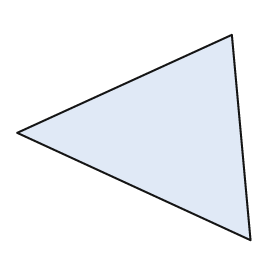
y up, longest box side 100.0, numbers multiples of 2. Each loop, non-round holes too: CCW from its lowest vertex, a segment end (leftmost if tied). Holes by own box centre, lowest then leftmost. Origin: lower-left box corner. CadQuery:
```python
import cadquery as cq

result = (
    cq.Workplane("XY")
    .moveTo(100.0, 0.0)
    .lineTo(92.0, 88.0)
    .lineTo(0.0, 46.0)
    .close()
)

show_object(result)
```